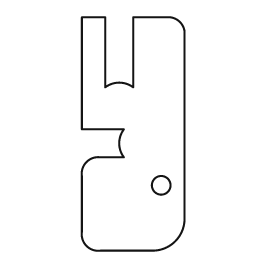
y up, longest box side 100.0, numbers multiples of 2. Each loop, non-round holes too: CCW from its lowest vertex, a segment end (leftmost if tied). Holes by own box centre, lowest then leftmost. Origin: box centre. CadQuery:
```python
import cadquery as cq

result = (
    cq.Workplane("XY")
    .moveTo(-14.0, -50.0)
    .lineTo(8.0, -50.0)
    .threePointArc((18.0, -46.0), (22.0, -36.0))
    .lineTo(22.0, 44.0)
    .threePointArc((20.0, 48.0), (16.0, 50.0))
    .lineTo(0.0, 50.0)
    .lineTo(0.0, 20.0)
    .threePointArc((-6.0, 22.0), (-12.0, 20.0))
    .lineTo(-12.0, 50.0)
    .lineTo(-22.0, 50.0)
    .lineTo(-22.0, 2.0)
    .lineTo(-4.0, 2.0)
    .threePointArc((-6.0, -4.0), (-4.0, -10.0))
    .lineTo(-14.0, -10.0)
    .threePointArc((-20.0, -12.0), (-22.0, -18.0))
    .lineTo(-22.0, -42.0)
    .threePointArc((-20.0, -48.0), (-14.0, -50.0))
    .close()
    .moveTo(12.0, -22.0)
    .circle(4.0)
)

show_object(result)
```